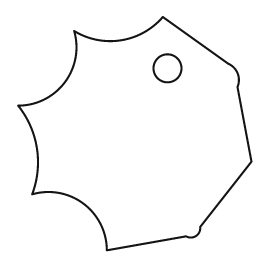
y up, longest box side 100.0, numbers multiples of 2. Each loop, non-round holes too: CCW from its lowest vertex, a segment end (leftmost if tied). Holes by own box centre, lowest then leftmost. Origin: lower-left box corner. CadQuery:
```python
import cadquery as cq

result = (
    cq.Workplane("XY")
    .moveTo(38.0, 0.0)
    .lineTo(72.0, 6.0)
    .threePointArc((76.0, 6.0), (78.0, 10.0))
    .lineTo(100.0, 38.0)
    .lineTo(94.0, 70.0)
    .threePointArc((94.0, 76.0), (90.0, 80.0))
    .lineTo(62.0, 100.0)
    .threePointArc((44.0, 90.0), (24.0, 94.0))
    .threePointArc((20.0, 72.0), (0.0, 62.0))
    .threePointArc((8.0, 44.0), (6.0, 24.0))
    .threePointArc((28.0, 20.0), (38.0, 0.0))
    .close()
    .moveTo(64.0, 78.0)
    .circle(6.0)
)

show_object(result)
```